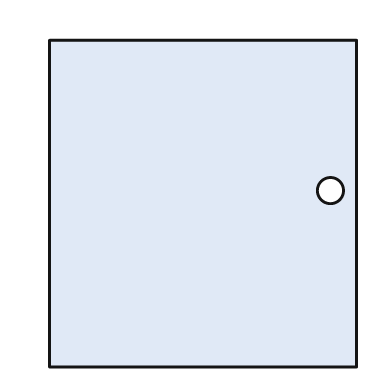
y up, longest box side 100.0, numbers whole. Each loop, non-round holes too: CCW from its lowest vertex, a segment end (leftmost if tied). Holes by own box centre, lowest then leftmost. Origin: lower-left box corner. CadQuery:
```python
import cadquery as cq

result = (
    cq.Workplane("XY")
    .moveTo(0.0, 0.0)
    .lineTo(94.0, 0.0)
    .lineTo(94.0, 100.0)
    .lineTo(0.0, 100.0)
    .close()
    .moveTo(86.0, 54.0)
    .circle(4.0)
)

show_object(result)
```